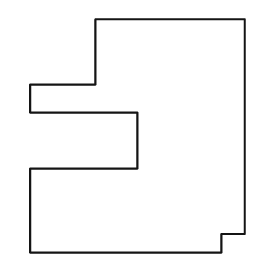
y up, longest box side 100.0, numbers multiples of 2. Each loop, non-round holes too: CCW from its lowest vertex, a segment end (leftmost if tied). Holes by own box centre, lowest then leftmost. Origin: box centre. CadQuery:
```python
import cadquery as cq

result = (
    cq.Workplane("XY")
    .moveTo(-46.0, -50.0)
    .lineTo(36.0, -50.0)
    .lineTo(36.0, -42.0)
    .lineTo(46.0, -42.0)
    .lineTo(46.0, 50.0)
    .lineTo(-18.0, 50.0)
    .lineTo(-18.0, 22.0)
    .lineTo(-46.0, 22.0)
    .lineTo(-46.0, 10.0)
    .lineTo(0.0, 10.0)
    .lineTo(0.0, -14.0)
    .lineTo(-46.0, -14.0)
    .close()
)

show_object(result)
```